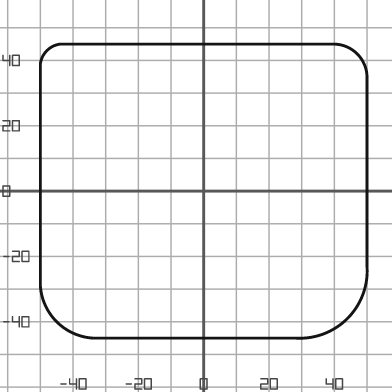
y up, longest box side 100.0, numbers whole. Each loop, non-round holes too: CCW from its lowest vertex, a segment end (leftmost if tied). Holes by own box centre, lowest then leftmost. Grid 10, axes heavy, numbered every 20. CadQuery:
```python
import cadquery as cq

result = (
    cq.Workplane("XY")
    .moveTo(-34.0, -45.0)
    .lineTo(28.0, -45.0)
    .threePointArc((44.0, -39.0), (50.0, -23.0))
    .lineTo(50.0, 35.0)
    .threePointArc((47.0, 42.0), (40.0, 45.0))
    .lineTo(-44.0, 45.0)
    .threePointArc((-48.0, 43.0), (-50.0, 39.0))
    .lineTo(-50.0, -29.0)
    .threePointArc((-45.0, -40.0), (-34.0, -45.0))
    .close()
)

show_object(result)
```